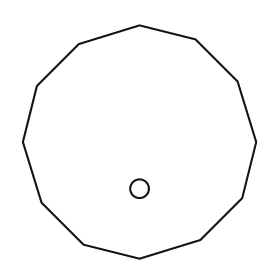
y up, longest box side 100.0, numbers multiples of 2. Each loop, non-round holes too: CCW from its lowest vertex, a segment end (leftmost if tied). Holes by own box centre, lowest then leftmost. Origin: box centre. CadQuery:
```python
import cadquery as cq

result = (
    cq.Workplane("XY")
    .moveTo(0.0, -50.0)
    .lineTo(26.0, -42.0)
    .lineTo(44.0, -24.0)
    .lineTo(50.0, 0.0)
    .lineTo(42.0, 26.0)
    .lineTo(24.0, 44.0)
    .lineTo(0.0, 50.0)
    .lineTo(-26.0, 42.0)
    .lineTo(-44.0, 24.0)
    .lineTo(-50.0, 0.0)
    .lineTo(-42.0, -26.0)
    .lineTo(-24.0, -44.0)
    .close()
    .moveTo(0.0, -20.0)
    .circle(4.0)
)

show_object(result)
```